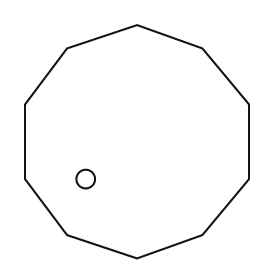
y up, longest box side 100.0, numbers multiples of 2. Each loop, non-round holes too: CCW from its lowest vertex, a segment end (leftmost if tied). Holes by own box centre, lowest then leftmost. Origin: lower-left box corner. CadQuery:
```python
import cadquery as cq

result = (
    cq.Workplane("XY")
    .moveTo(48.0, 0.0)
    .lineTo(76.0, 10.0)
    .lineTo(96.0, 34.0)
    .lineTo(96.0, 66.0)
    .lineTo(76.0, 90.0)
    .lineTo(48.0, 100.0)
    .lineTo(18.0, 90.0)
    .lineTo(0.0, 66.0)
    .lineTo(0.0, 34.0)
    .lineTo(18.0, 10.0)
    .close()
    .moveTo(26.0, 34.0)
    .circle(4.0)
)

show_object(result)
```